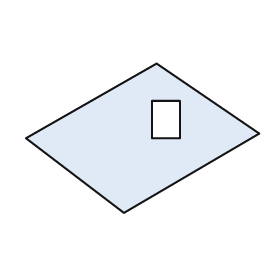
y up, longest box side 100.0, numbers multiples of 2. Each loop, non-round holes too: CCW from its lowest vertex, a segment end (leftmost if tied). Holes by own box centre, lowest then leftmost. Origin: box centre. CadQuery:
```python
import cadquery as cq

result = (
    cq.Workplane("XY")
    .moveTo(-8.0, -32.0)
    .lineTo(50.0, 2.0)
    .lineTo(6.0, 32.0)
    .lineTo(-50.0, 0.0)
    .close()
    .moveTo(4.0, 0.0)
    .lineTo(16.0, 0.0)
    .lineTo(16.0, 16.0)
    .lineTo(4.0, 16.0)
    .close()
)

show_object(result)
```